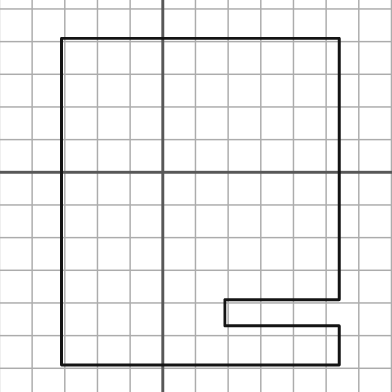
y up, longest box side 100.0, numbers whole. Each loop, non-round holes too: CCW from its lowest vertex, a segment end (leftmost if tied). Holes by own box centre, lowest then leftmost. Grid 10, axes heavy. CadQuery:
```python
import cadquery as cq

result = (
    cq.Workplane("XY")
    .moveTo(-31.0, -59.0)
    .lineTo(54.0, -59.0)
    .lineTo(54.0, -47.0)
    .lineTo(19.0, -47.0)
    .lineTo(19.0, -39.0)
    .lineTo(54.0, -39.0)
    .lineTo(54.0, 41.0)
    .lineTo(-31.0, 41.0)
    .close()
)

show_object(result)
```